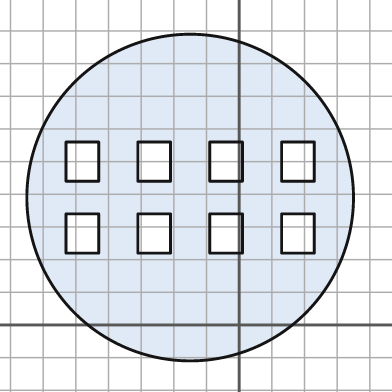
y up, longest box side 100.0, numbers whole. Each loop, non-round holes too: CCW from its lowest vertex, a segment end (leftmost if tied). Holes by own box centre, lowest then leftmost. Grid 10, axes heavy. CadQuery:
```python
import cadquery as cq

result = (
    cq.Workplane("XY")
    .moveTo(-15.0, 39.0)
    .circle(50.0)
    .moveTo(-53.0, 22.0)
    .lineTo(-43.0, 22.0)
    .lineTo(-43.0, 34.0)
    .lineTo(-53.0, 34.0)
    .close()
    .moveTo(-31.0, 22.0)
    .lineTo(-21.0, 22.0)
    .lineTo(-21.0, 34.0)
    .lineTo(-31.0, 34.0)
    .close()
    .moveTo(-9.0, 22.0)
    .lineTo(1.0, 22.0)
    .lineTo(1.0, 34.0)
    .lineTo(-9.0, 34.0)
    .close()
    .moveTo(13.0, 22.0)
    .lineTo(23.0, 22.0)
    .lineTo(23.0, 34.0)
    .lineTo(13.0, 34.0)
    .close()
    .moveTo(-53.0, 44.0)
    .lineTo(-43.0, 44.0)
    .lineTo(-43.0, 56.0)
    .lineTo(-53.0, 56.0)
    .close()
    .moveTo(-31.0, 44.0)
    .lineTo(-21.0, 44.0)
    .lineTo(-21.0, 56.0)
    .lineTo(-31.0, 56.0)
    .close()
    .moveTo(-9.0, 44.0)
    .lineTo(1.0, 44.0)
    .lineTo(1.0, 56.0)
    .lineTo(-9.0, 56.0)
    .close()
    .moveTo(13.0, 44.0)
    .lineTo(23.0, 44.0)
    .lineTo(23.0, 56.0)
    .lineTo(13.0, 56.0)
    .close()
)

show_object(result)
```